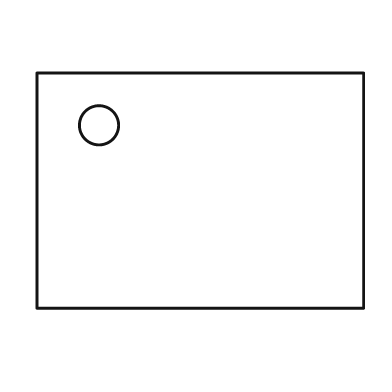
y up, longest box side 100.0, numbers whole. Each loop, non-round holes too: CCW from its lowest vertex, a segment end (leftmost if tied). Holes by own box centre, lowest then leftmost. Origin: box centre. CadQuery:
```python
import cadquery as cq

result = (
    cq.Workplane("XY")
    .moveTo(-50.0, -36.0)
    .lineTo(50.0, -36.0)
    .lineTo(50.0, 36.0)
    .lineTo(-50.0, 36.0)
    .close()
    .moveTo(-31.0, 20.0)
    .circle(6.0)
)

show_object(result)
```